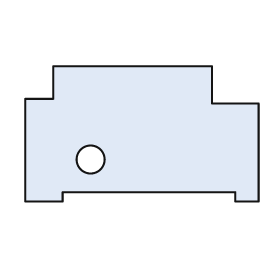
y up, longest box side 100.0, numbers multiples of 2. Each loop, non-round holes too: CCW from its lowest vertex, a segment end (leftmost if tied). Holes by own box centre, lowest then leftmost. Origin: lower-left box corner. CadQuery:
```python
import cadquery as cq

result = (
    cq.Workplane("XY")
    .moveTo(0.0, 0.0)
    .lineTo(16.0, 0.0)
    .lineTo(16.0, 4.0)
    .lineTo(90.0, 4.0)
    .lineTo(90.0, 0.0)
    .lineTo(100.0, 0.0)
    .lineTo(100.0, 42.0)
    .lineTo(80.0, 42.0)
    .lineTo(80.0, 58.0)
    .lineTo(12.0, 58.0)
    .lineTo(12.0, 44.0)
    .lineTo(0.0, 44.0)
    .close()
    .moveTo(28.0, 18.0)
    .circle(6.0)
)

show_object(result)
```